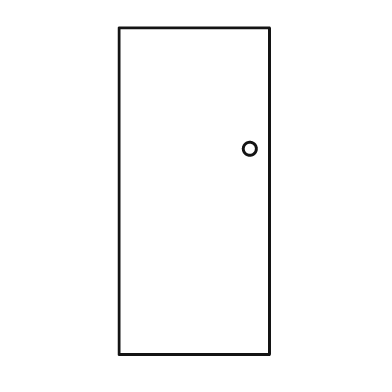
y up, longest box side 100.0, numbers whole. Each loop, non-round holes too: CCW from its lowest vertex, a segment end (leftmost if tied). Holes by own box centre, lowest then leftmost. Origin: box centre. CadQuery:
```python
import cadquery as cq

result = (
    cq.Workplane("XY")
    .moveTo(-23.0, -50.0)
    .lineTo(23.0, -50.0)
    .lineTo(23.0, 50.0)
    .lineTo(-23.0, 50.0)
    .close()
    .moveTo(17.0, 13.0)
    .circle(2.0)
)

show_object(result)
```